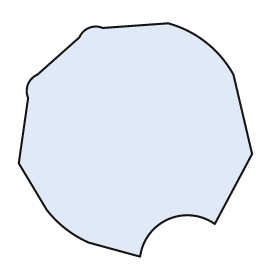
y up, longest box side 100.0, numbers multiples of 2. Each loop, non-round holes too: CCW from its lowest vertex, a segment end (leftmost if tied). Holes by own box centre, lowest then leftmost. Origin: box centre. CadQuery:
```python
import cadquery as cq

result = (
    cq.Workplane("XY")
    .moveTo(2.0, -50.0)
    .threePointArc((14.0, -34.0), (34.0, -36.0))
    .lineTo(50.0, -6.0)
    .lineTo(42.0, 28.0)
    .threePointArc((30.0, 42.0), (14.0, 50.0))
    .lineTo(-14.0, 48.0)
    .threePointArc((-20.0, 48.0), (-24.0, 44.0))
    .lineTo(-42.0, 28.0)
    .threePointArc((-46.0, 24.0), (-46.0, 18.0))
    .lineTo(-50.0, -10.0)
    .lineTo(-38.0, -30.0)
    .threePointArc((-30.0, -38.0), (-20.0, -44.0))
    .close()
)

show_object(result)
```